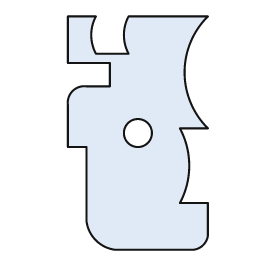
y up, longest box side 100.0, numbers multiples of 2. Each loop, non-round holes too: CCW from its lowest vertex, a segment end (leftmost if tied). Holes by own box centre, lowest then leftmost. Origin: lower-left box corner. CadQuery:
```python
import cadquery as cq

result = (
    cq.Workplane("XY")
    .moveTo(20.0, 0.0)
    .lineTo(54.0, 0.0)
    .threePointArc((58.0, 2.0), (60.0, 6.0))
    .lineTo(60.0, 20.0)
    .lineTo(48.0, 20.0)
    .threePointArc((52.0, 36.0), (48.0, 52.0))
    .lineTo(60.0, 52.0)
    .threePointArc((50.0, 76.0), (60.0, 100.0))
    .lineTo(26.0, 100.0)
    .threePointArc((24.0, 92.0), (26.0, 84.0))
    .lineTo(12.0, 84.0)
    .threePointArc((10.0, 92.0), (12.0, 100.0))
    .lineTo(0.0, 100.0)
    .lineTo(0.0, 80.0)
    .lineTo(18.0, 80.0)
    .lineTo(18.0, 70.0)
    .lineTo(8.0, 70.0)
    .threePointArc((2.0, 68.0), (0.0, 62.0))
    .lineTo(0.0, 44.0)
    .lineTo(8.0, 44.0)
    .lineTo(8.0, 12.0)
    .threePointArc((12.0, 4.0), (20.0, 0.0))
    .close()
    .moveTo(30.0, 50.0)
    .circle(6.0)
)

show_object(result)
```